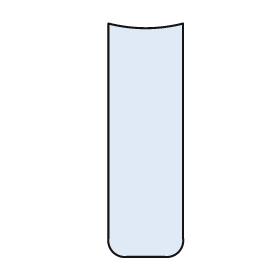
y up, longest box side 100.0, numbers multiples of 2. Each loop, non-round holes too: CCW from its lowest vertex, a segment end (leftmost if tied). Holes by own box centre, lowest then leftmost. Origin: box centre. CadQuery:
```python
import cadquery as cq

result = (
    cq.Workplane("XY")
    .moveTo(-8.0, -50.0)
    .lineTo(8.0, -50.0)
    .threePointArc((14.0, -48.0), (16.0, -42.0))
    .lineTo(16.0, 50.0)
    .threePointArc((0.0, 48.0), (-16.0, 50.0))
    .lineTo(-16.0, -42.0)
    .threePointArc((-14.0, -48.0), (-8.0, -50.0))
    .close()
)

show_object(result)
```